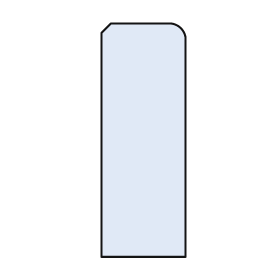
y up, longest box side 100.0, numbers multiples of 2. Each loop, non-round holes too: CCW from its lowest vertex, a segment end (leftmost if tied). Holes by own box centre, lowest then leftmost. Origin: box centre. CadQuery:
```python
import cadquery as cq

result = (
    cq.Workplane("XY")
    .moveTo(-18.0, -50.0)
    .lineTo(18.0, -50.0)
    .lineTo(18.0, 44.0)
    .threePointArc((16.0, 48.0), (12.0, 50.0))
    .lineTo(-14.0, 50.0)
    .lineTo(-18.0, 46.0)
    .close()
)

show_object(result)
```